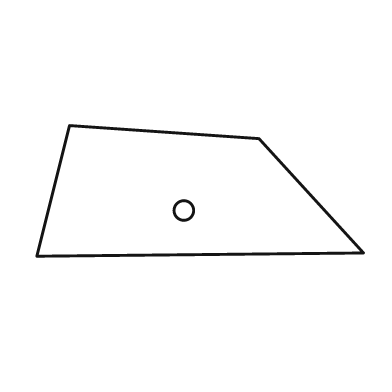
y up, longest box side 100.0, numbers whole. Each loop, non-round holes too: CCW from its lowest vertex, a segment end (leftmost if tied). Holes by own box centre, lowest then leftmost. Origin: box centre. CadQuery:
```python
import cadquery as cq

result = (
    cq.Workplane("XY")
    .moveTo(-50.0, -20.0)
    .lineTo(50.0, -19.0)
    .lineTo(18.0, 16.0)
    .lineTo(-40.0, 20.0)
    .close()
    .moveTo(-5.0, -6.0)
    .circle(3.0)
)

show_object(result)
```